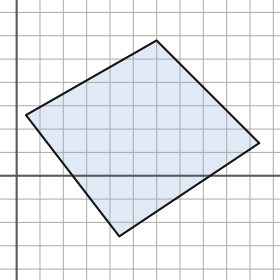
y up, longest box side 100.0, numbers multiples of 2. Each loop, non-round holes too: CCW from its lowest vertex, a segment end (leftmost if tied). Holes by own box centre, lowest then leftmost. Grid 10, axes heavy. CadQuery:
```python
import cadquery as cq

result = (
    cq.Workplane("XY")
    .moveTo(44.0, -26.0)
    .lineTo(104.0, 14.0)
    .lineTo(60.0, 58.0)
    .lineTo(4.0, 26.0)
    .close()
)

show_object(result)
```